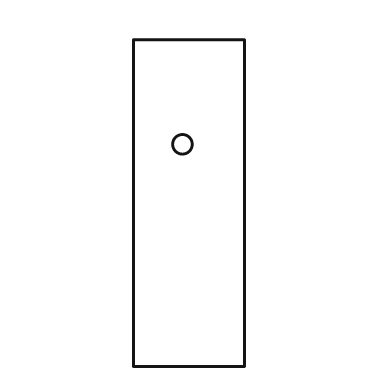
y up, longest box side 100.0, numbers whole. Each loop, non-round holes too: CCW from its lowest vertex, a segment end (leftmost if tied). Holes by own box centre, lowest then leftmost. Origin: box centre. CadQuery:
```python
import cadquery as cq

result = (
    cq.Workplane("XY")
    .moveTo(-17.0, -50.0)
    .lineTo(17.0, -50.0)
    .lineTo(17.0, 50.0)
    .lineTo(-17.0, 50.0)
    .close()
    .moveTo(-2.0, 18.0)
    .circle(3.0)
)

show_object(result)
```